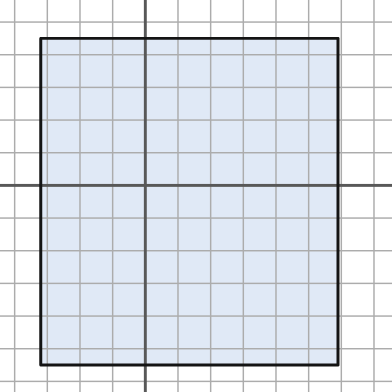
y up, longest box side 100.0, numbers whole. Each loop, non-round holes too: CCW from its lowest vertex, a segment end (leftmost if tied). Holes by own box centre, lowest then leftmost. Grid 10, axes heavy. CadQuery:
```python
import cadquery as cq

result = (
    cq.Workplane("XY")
    .moveTo(-32.0, -55.0)
    .lineTo(59.0, -55.0)
    .lineTo(59.0, 45.0)
    .lineTo(-32.0, 45.0)
    .close()
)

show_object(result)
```